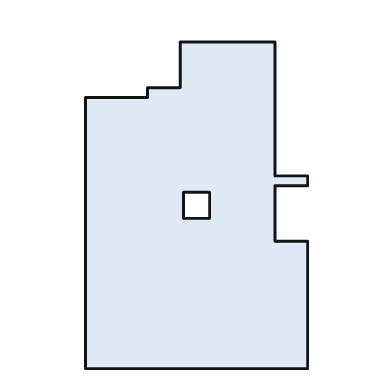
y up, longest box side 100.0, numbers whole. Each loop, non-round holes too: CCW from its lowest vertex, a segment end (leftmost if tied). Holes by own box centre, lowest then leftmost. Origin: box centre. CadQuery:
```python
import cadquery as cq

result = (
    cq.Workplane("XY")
    .moveTo(-34.0, -50.0)
    .lineTo(34.0, -50.0)
    .lineTo(34.0, -11.0)
    .lineTo(24.0, -11.0)
    .lineTo(24.0, 6.0)
    .lineTo(34.0, 6.0)
    .lineTo(34.0, 9.0)
    .lineTo(24.0, 9.0)
    .lineTo(24.0, 50.0)
    .lineTo(-5.0, 50.0)
    .lineTo(-5.0, 36.0)
    .lineTo(-15.0, 36.0)
    .lineTo(-15.0, 33.0)
    .lineTo(-34.0, 33.0)
    .close()
    .moveTo(-4.0, -4.0)
    .lineTo(4.0, -4.0)
    .lineTo(4.0, 4.0)
    .lineTo(-4.0, 4.0)
    .close()
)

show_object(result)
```